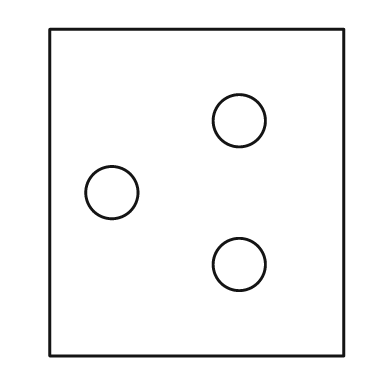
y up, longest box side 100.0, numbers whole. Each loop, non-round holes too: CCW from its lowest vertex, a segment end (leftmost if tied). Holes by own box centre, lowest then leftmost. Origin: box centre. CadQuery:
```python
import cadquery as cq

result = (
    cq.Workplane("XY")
    .moveTo(-45.0, -50.0)
    .lineTo(45.0, -50.0)
    .lineTo(45.0, 50.0)
    .lineTo(-45.0, 50.0)
    .close()
    .moveTo(13.0, -22.0)
    .circle(8.0)
    .moveTo(-26.0, 0.0)
    .circle(8.0)
    .moveTo(13.0, 22.0)
    .circle(8.0)
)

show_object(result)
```